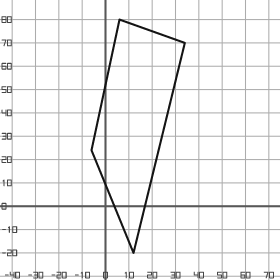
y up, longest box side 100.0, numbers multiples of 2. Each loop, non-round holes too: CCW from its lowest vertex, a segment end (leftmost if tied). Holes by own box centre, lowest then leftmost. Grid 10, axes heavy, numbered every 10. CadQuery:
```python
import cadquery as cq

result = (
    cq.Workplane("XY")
    .moveTo(12.0, -20.0)
    .lineTo(34.0, 70.0)
    .lineTo(6.0, 80.0)
    .lineTo(-6.0, 24.0)
    .close()
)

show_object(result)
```